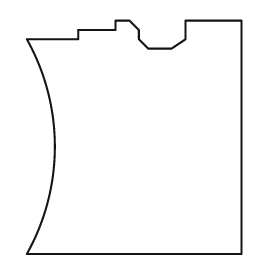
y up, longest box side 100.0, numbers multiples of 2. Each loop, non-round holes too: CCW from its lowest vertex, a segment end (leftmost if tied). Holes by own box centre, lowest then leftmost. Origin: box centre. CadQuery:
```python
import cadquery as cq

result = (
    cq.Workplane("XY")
    .moveTo(-46.0, -50.0)
    .lineTo(46.0, -50.0)
    .lineTo(46.0, 50.0)
    .lineTo(22.0, 50.0)
    .lineTo(22.0, 42.0)
    .lineTo(16.0, 38.0)
    .lineTo(6.0, 38.0)
    .lineTo(2.0, 42.0)
    .lineTo(2.0, 46.0)
    .lineTo(-2.0, 50.0)
    .lineTo(-8.0, 50.0)
    .lineTo(-8.0, 46.0)
    .lineTo(-24.0, 46.0)
    .lineTo(-24.0, 42.0)
    .lineTo(-46.0, 42.0)
    .threePointArc((-34.0, -4.0), (-46.0, -50.0))
    .close()
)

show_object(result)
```